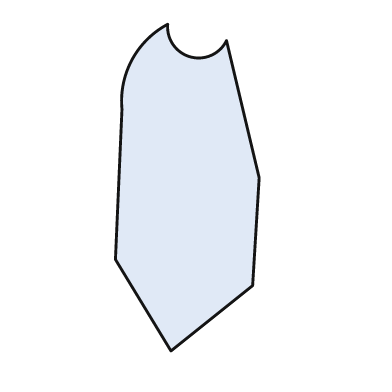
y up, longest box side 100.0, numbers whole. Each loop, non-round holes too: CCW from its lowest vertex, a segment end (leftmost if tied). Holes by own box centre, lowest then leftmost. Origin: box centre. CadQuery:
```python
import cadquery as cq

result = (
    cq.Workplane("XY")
    .moveTo(-5.0, -50.0)
    .lineTo(20.0, -30.0)
    .lineTo(22.0, 3.0)
    .lineTo(12.0, 45.0)
    .threePointArc((1.0, 40.0), (-6.0, 50.0))
    .threePointArc((-17.0, 39.0), (-20.0, 24.0))
    .lineTo(-22.0, -22.0)
    .close()
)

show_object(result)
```